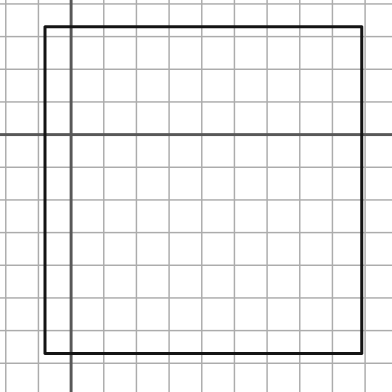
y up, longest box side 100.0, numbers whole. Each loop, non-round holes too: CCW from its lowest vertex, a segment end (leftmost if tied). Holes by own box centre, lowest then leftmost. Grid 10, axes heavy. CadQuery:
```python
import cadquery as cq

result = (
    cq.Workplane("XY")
    .moveTo(-8.0, -67.0)
    .lineTo(89.0, -67.0)
    .lineTo(89.0, 33.0)
    .lineTo(-8.0, 33.0)
    .close()
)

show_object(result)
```